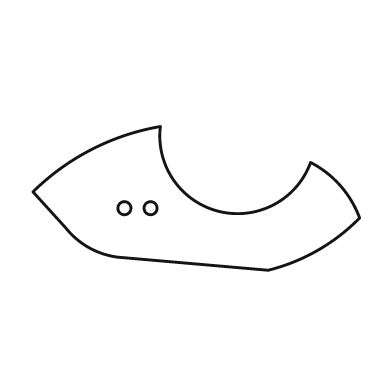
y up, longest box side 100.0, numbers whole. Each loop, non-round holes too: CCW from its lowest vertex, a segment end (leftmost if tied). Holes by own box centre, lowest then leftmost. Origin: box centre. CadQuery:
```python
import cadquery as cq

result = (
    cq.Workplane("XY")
    .moveTo(22.0, -22.0)
    .threePointArc((37.0, -16.0), (50.0, -6.0))
    .threePointArc((44.0, 4.0), (35.0, 11.0))
    .threePointArc((7.0, -4.0), (-11.0, 22.0))
    .threePointArc((-32.0, 15.0), (-50.0, 2.0))
    .lineTo(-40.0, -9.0)
    .threePointArc((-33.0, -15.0), (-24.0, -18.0))
    .close()
    .moveTo(-22.0, -3.0)
    .circle(2.0)
    .moveTo(-14.0, -3.0)
    .circle(2.0)
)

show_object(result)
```